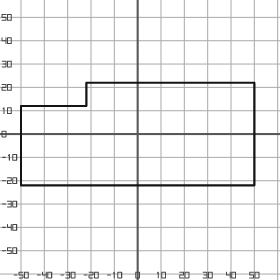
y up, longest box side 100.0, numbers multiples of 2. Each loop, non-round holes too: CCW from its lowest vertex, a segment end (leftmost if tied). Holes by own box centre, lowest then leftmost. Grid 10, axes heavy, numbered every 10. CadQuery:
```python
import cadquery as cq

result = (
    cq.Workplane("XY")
    .moveTo(-50.0, -22.0)
    .lineTo(50.0, -22.0)
    .lineTo(50.0, 22.0)
    .lineTo(-22.0, 22.0)
    .lineTo(-22.0, 12.0)
    .lineTo(-50.0, 12.0)
    .close()
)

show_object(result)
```